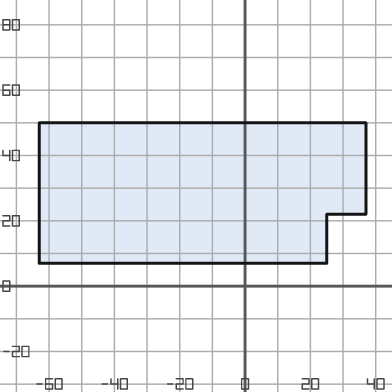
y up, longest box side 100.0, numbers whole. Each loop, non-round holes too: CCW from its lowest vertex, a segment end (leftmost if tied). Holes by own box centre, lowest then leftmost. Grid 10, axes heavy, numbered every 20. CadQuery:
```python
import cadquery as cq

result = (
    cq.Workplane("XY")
    .moveTo(-63.0, 7.0)
    .lineTo(25.0, 7.0)
    .lineTo(25.0, 22.0)
    .lineTo(37.0, 22.0)
    .lineTo(37.0, 50.0)
    .lineTo(-63.0, 50.0)
    .close()
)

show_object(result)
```